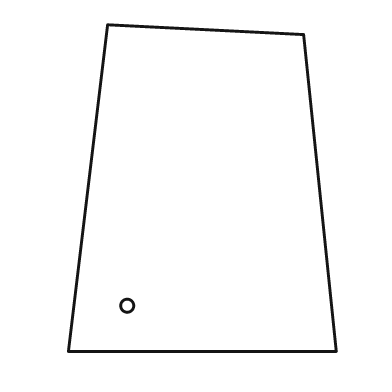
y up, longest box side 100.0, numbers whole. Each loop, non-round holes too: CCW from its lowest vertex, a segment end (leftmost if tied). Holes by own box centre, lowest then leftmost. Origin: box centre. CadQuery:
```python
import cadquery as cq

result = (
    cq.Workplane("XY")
    .moveTo(-41.0, -50.0)
    .lineTo(41.0, -50.0)
    .lineTo(31.0, 47.0)
    .lineTo(-29.0, 50.0)
    .close()
    .moveTo(-23.0, -36.0)
    .circle(2.0)
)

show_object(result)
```